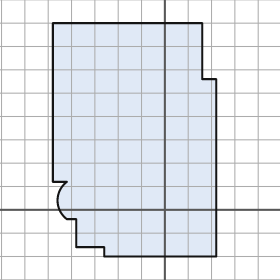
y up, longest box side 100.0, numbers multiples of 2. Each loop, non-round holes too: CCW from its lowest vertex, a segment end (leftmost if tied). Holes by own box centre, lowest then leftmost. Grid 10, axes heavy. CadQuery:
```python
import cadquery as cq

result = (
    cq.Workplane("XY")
    .moveTo(-26.0, -20.0)
    .lineTo(22.0, -20.0)
    .lineTo(22.0, 56.0)
    .lineTo(16.0, 56.0)
    .lineTo(16.0, 80.0)
    .lineTo(-48.0, 80.0)
    .lineTo(-48.0, 12.0)
    .lineTo(-42.0, 12.0)
    .threePointArc((-46.0, 4.0), (-42.0, -4.0))
    .lineTo(-38.0, -4.0)
    .lineTo(-38.0, -16.0)
    .lineTo(-26.0, -16.0)
    .close()
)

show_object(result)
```